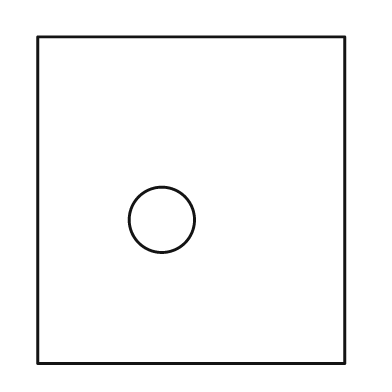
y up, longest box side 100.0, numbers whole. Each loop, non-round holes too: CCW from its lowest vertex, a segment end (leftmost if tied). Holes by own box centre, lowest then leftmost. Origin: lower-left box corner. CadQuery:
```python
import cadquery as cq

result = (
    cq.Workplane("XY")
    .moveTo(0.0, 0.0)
    .lineTo(94.0, 0.0)
    .lineTo(94.0, 100.0)
    .lineTo(0.0, 100.0)
    .close()
    .moveTo(38.0, 44.0)
    .circle(10.0)
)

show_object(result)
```